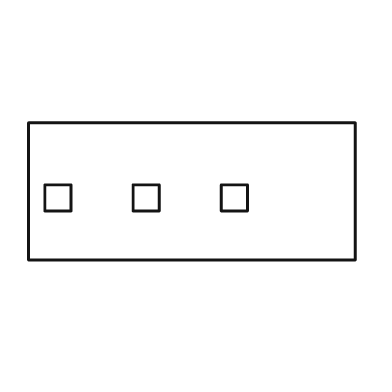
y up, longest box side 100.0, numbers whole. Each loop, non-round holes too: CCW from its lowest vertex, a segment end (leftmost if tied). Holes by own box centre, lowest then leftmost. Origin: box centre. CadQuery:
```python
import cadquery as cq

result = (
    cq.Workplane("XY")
    .moveTo(-50.0, -21.0)
    .lineTo(50.0, -21.0)
    .lineTo(50.0, 21.0)
    .lineTo(-50.0, 21.0)
    .close()
    .moveTo(-45.0, -6.0)
    .lineTo(-37.0, -6.0)
    .lineTo(-37.0, 2.0)
    .lineTo(-45.0, 2.0)
    .close()
    .moveTo(-18.0, -6.0)
    .lineTo(-10.0, -6.0)
    .lineTo(-10.0, 2.0)
    .lineTo(-18.0, 2.0)
    .close()
    .moveTo(9.0, -6.0)
    .lineTo(17.0, -6.0)
    .lineTo(17.0, 2.0)
    .lineTo(9.0, 2.0)
    .close()
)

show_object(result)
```